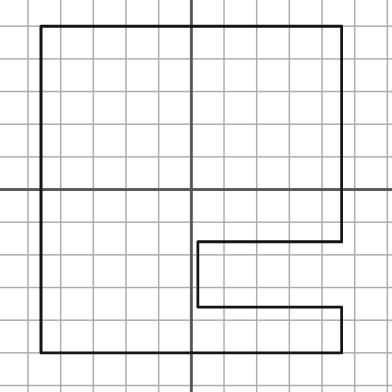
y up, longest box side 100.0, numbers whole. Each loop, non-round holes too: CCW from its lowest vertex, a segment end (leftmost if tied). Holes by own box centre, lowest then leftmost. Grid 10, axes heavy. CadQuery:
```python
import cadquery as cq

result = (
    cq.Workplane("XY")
    .moveTo(-46.0, -50.0)
    .lineTo(46.0, -50.0)
    .lineTo(46.0, -36.0)
    .lineTo(2.0, -36.0)
    .lineTo(2.0, -16.0)
    .lineTo(46.0, -16.0)
    .lineTo(46.0, 50.0)
    .lineTo(-46.0, 50.0)
    .close()
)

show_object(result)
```